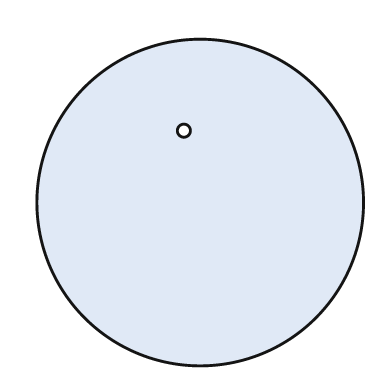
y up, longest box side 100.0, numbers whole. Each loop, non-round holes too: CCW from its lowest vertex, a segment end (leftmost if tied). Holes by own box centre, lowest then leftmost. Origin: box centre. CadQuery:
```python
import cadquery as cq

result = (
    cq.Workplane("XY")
    .moveTo(0.0, 0.0)
    .circle(50.0)
    .moveTo(-5.0, 22.0)
    .circle(2.0)
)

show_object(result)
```